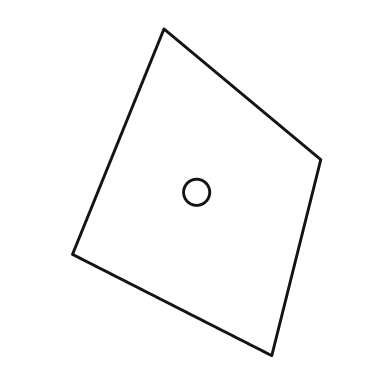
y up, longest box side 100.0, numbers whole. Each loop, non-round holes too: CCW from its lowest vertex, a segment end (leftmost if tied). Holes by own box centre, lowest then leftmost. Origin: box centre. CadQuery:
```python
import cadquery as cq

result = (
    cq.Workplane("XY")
    .moveTo(23.0, -50.0)
    .lineTo(38.0, 10.0)
    .lineTo(-10.0, 50.0)
    .lineTo(-38.0, -19.0)
    .close()
    .moveTo(0.0, 0.0)
    .circle(4.0)
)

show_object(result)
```